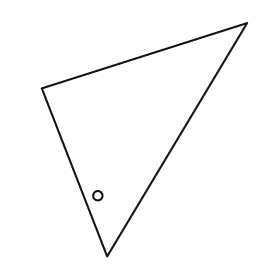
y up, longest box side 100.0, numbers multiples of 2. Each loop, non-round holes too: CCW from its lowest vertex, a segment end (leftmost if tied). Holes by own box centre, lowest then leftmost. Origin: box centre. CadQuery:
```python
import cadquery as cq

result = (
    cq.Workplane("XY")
    .moveTo(-16.0, -50.0)
    .lineTo(44.0, 50.0)
    .lineTo(-44.0, 22.0)
    .close()
    .moveTo(-20.0, -24.0)
    .circle(2.0)
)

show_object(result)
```